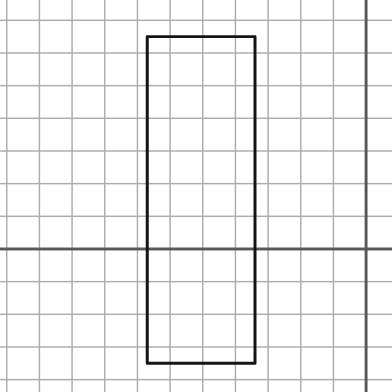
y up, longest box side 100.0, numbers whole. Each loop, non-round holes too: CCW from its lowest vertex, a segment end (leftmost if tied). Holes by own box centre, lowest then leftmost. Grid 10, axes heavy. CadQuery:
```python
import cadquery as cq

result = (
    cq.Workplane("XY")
    .moveTo(-67.0, -35.0)
    .lineTo(-34.0, -35.0)
    .lineTo(-34.0, 65.0)
    .lineTo(-67.0, 65.0)
    .close()
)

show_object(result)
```